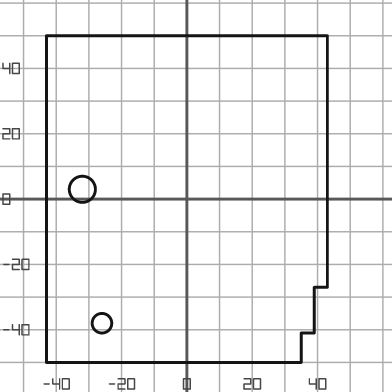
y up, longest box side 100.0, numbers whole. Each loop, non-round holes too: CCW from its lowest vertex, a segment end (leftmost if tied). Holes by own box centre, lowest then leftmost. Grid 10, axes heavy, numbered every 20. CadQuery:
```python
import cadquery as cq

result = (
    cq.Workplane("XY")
    .moveTo(-43.0, -50.0)
    .lineTo(35.0, -50.0)
    .lineTo(35.0, -41.0)
    .lineTo(39.0, -41.0)
    .lineTo(39.0, -27.0)
    .lineTo(43.0, -27.0)
    .lineTo(43.0, 50.0)
    .lineTo(-43.0, 50.0)
    .close()
    .moveTo(-26.0, -38.0)
    .circle(3.0)
    .moveTo(-32.0, 3.0)
    .circle(4.0)
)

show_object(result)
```